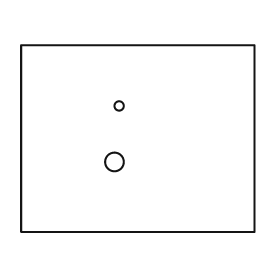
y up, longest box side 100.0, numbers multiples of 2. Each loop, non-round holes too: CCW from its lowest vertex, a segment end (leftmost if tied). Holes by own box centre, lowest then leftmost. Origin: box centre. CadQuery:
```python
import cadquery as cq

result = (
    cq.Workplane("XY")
    .moveTo(-50.0, -40.0)
    .lineTo(50.0, -40.0)
    .lineTo(50.0, 40.0)
    .lineTo(-50.0, 40.0)
    .close()
    .moveTo(-10.0, -10.0)
    .circle(4.0)
    .moveTo(-8.0, 14.0)
    .circle(2.0)
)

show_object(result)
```